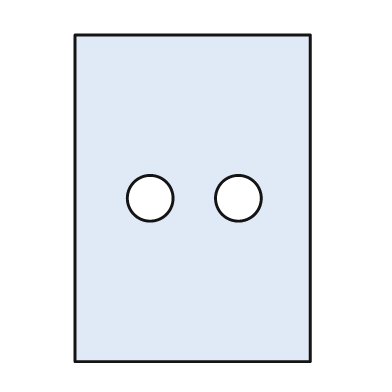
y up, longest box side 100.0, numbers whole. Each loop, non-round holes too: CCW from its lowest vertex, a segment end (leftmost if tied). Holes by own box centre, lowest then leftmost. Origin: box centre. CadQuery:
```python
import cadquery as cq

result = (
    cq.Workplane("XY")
    .moveTo(-36.0, -50.0)
    .lineTo(36.0, -50.0)
    .lineTo(36.0, 50.0)
    .lineTo(-36.0, 50.0)
    .close()
    .moveTo(-13.0, 0.0)
    .circle(7.0)
    .moveTo(14.0, 0.0)
    .circle(7.0)
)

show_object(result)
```